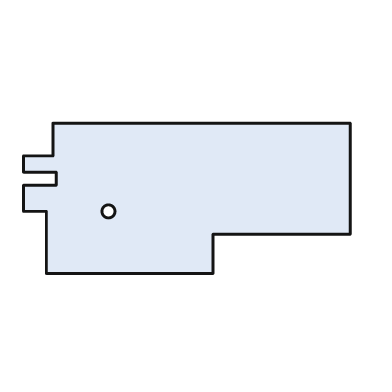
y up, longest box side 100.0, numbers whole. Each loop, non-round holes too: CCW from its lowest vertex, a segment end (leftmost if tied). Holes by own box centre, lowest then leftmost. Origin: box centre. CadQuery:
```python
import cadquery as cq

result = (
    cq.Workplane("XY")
    .moveTo(-43.0, -23.0)
    .lineTo(8.0, -23.0)
    .lineTo(8.0, -11.0)
    .lineTo(50.0, -11.0)
    .lineTo(50.0, 23.0)
    .lineTo(-41.0, 23.0)
    .lineTo(-41.0, 13.0)
    .lineTo(-50.0, 13.0)
    .lineTo(-50.0, 8.0)
    .lineTo(-40.0, 8.0)
    .lineTo(-40.0, 4.0)
    .lineTo(-50.0, 4.0)
    .lineTo(-50.0, -4.0)
    .lineTo(-43.0, -4.0)
    .close()
    .moveTo(-24.0, -4.0)
    .circle(2.0)
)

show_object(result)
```